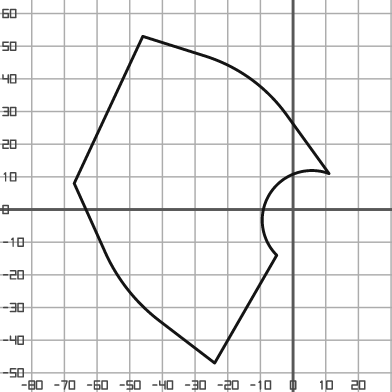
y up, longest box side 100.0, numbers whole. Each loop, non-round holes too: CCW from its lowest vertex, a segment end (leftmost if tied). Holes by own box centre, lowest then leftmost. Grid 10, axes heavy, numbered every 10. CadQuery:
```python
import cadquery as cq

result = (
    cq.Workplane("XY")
    .moveTo(-24.0, -47.0)
    .lineTo(-5.0, -14.0)
    .threePointArc((-7.0, 5.0), (11.0, 11.0))
    .lineTo(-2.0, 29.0)
    .threePointArc((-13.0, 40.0), (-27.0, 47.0))
    .lineTo(-46.0, 53.0)
    .lineTo(-67.0, 8.0)
    .lineTo(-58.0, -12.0)
    .threePointArc((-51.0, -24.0), (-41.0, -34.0))
    .close()
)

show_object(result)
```